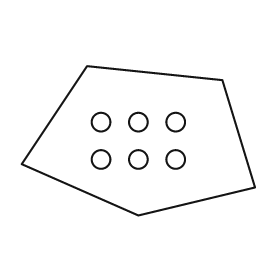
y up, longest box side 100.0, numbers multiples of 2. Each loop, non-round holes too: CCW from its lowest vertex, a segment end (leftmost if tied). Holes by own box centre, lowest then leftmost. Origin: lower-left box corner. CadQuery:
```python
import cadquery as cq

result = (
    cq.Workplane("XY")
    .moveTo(50.0, 0.0)
    .lineTo(100.0, 12.0)
    .lineTo(86.0, 58.0)
    .lineTo(28.0, 64.0)
    .lineTo(0.0, 22.0)
    .close()
    .moveTo(34.0, 24.0)
    .circle(4.0)
    .moveTo(50.0, 24.0)
    .circle(4.0)
    .moveTo(66.0, 24.0)
    .circle(4.0)
    .moveTo(34.0, 40.0)
    .circle(4.0)
    .moveTo(50.0, 40.0)
    .circle(4.0)
    .moveTo(66.0, 40.0)
    .circle(4.0)
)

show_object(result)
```